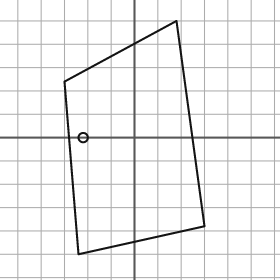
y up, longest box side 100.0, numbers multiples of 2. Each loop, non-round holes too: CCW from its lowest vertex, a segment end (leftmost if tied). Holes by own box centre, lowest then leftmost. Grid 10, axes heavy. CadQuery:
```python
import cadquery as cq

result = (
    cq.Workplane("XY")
    .moveTo(-24.0, -50.0)
    .lineTo(30.0, -38.0)
    .lineTo(18.0, 50.0)
    .lineTo(-30.0, 24.0)
    .close()
    .moveTo(-22.0, 0.0)
    .circle(2.0)
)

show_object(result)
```